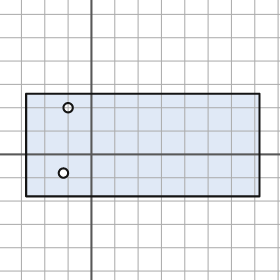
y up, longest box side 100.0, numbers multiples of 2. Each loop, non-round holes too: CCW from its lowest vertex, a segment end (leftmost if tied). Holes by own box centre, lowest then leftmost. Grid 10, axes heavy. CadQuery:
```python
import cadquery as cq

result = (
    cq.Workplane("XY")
    .moveTo(-28.0, -18.0)
    .lineTo(72.0, -18.0)
    .lineTo(72.0, 26.0)
    .lineTo(-28.0, 26.0)
    .close()
    .moveTo(-12.0, -8.0)
    .circle(2.0)
    .moveTo(-10.0, 20.0)
    .circle(2.0)
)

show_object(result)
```